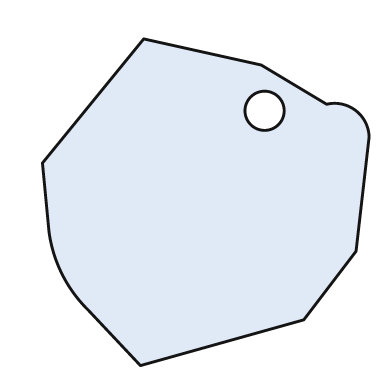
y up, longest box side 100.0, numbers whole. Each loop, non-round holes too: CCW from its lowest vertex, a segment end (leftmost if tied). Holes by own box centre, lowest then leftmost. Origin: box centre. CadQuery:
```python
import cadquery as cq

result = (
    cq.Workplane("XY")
    .moveTo(-20.0, -50.0)
    .lineTo(30.0, -36.0)
    .lineTo(46.0, -15.0)
    .lineTo(50.0, 20.0)
    .threePointArc((46.0, 28.0), (37.0, 30.0))
    .lineTo(17.0, 42.0)
    .lineTo(-19.0, 50.0)
    .lineTo(-50.0, 12.0)
    .lineTo(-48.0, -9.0)
    .threePointArc((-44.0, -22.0), (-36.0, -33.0))
    .close()
    .moveTo(18.0, 28.0)
    .circle(6.0)
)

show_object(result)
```